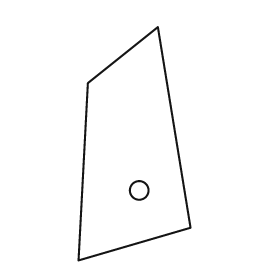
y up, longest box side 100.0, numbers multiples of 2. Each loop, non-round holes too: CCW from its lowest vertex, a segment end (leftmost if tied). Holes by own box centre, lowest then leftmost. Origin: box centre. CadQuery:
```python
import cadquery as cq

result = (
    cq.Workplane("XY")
    .moveTo(-24.0, -50.0)
    .lineTo(24.0, -36.0)
    .lineTo(10.0, 50.0)
    .lineTo(-20.0, 26.0)
    .close()
    .moveTo(2.0, -20.0)
    .circle(4.0)
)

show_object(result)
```